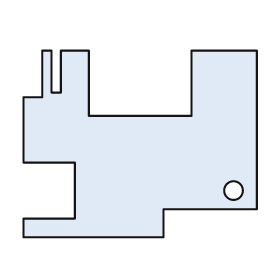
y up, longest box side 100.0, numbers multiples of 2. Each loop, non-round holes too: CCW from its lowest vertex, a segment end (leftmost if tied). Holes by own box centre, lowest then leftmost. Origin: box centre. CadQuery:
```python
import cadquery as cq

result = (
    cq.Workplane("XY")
    .moveTo(-50.0, -40.0)
    .lineTo(10.0, -40.0)
    .lineTo(10.0, -28.0)
    .lineTo(50.0, -28.0)
    .lineTo(50.0, 40.0)
    .lineTo(22.0, 40.0)
    .lineTo(22.0, 12.0)
    .lineTo(-22.0, 12.0)
    .lineTo(-22.0, 40.0)
    .lineTo(-34.0, 40.0)
    .lineTo(-34.0, 22.0)
    .lineTo(-38.0, 22.0)
    .lineTo(-38.0, 40.0)
    .lineTo(-42.0, 40.0)
    .lineTo(-42.0, 20.0)
    .lineTo(-50.0, 20.0)
    .lineTo(-50.0, -8.0)
    .lineTo(-28.0, -8.0)
    .lineTo(-28.0, -32.0)
    .lineTo(-50.0, -32.0)
    .close()
    .moveTo(40.0, -20.0)
    .circle(4.0)
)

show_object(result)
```